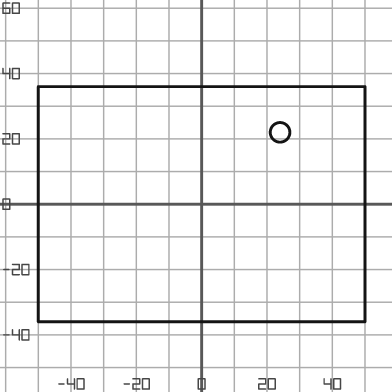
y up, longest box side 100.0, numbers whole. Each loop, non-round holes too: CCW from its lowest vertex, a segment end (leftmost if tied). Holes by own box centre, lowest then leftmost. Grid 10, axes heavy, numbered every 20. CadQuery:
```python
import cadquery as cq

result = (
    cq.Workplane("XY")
    .moveTo(-50.0, -36.0)
    .lineTo(50.0, -36.0)
    .lineTo(50.0, 36.0)
    .lineTo(-50.0, 36.0)
    .close()
    .moveTo(24.0, 22.0)
    .circle(3.0)
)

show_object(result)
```